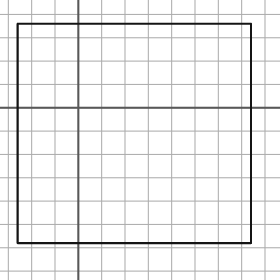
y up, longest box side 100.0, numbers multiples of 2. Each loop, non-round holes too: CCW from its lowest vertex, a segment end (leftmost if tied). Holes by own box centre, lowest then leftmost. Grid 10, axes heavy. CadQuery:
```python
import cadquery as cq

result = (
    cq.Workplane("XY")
    .moveTo(-26.0, -58.0)
    .lineTo(74.0, -58.0)
    .lineTo(74.0, 36.0)
    .lineTo(-26.0, 36.0)
    .close()
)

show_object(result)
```